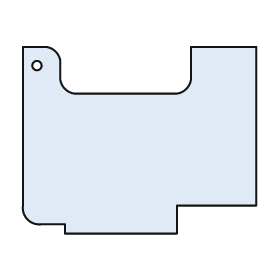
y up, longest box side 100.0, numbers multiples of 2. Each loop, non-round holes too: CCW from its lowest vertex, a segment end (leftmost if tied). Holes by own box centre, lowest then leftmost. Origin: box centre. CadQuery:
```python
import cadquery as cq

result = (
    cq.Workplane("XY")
    .moveTo(-32.0, -40.0)
    .lineTo(16.0, -40.0)
    .lineTo(16.0, -28.0)
    .lineTo(50.0, -28.0)
    .lineTo(50.0, 40.0)
    .lineTo(22.0, 40.0)
    .lineTo(22.0, 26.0)
    .threePointArc((20.0, 22.0), (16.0, 20.0))
    .lineTo(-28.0, 20.0)
    .threePointArc((-32.0, 22.0), (-34.0, 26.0))
    .lineTo(-34.0, 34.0)
    .threePointArc((-36.0, 38.0), (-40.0, 40.0))
    .lineTo(-50.0, 40.0)
    .lineTo(-50.0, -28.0)
    .threePointArc((-48.0, -34.0), (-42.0, -36.0))
    .lineTo(-32.0, -36.0)
    .close()
    .moveTo(-44.0, 32.0)
    .circle(2.0)
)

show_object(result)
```